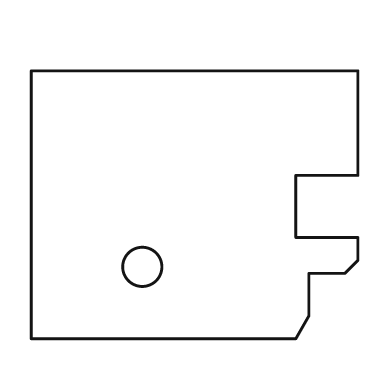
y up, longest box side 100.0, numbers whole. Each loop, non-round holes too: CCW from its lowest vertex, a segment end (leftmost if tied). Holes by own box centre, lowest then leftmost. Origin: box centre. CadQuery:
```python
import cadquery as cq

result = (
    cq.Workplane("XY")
    .moveTo(-50.0, -41.0)
    .lineTo(31.0, -41.0)
    .lineTo(35.0, -34.0)
    .lineTo(35.0, -21.0)
    .lineTo(46.0, -21.0)
    .lineTo(50.0, -17.0)
    .lineTo(50.0, -10.0)
    .lineTo(31.0, -10.0)
    .lineTo(31.0, 9.0)
    .lineTo(50.0, 9.0)
    .lineTo(50.0, 41.0)
    .lineTo(-50.0, 41.0)
    .close()
    .moveTo(-16.0, -19.0)
    .circle(6.0)
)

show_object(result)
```